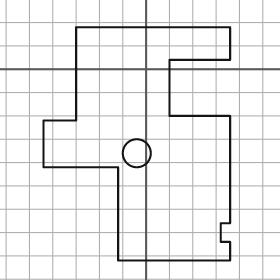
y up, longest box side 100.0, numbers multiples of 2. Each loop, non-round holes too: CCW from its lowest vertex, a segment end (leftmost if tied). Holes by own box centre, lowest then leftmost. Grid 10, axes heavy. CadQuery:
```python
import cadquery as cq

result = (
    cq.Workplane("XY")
    .moveTo(-12.0, -82.0)
    .lineTo(36.0, -82.0)
    .lineTo(36.0, -74.0)
    .lineTo(32.0, -74.0)
    .lineTo(32.0, -66.0)
    .lineTo(36.0, -66.0)
    .lineTo(36.0, -20.0)
    .lineTo(10.0, -20.0)
    .lineTo(10.0, 4.0)
    .lineTo(36.0, 4.0)
    .lineTo(36.0, 18.0)
    .lineTo(-30.0, 18.0)
    .lineTo(-30.0, -22.0)
    .lineTo(-44.0, -22.0)
    .lineTo(-44.0, -42.0)
    .lineTo(-12.0, -42.0)
    .close()
    .moveTo(-4.0, -36.0)
    .circle(6.0)
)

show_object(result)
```